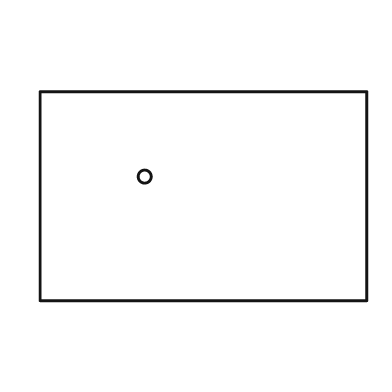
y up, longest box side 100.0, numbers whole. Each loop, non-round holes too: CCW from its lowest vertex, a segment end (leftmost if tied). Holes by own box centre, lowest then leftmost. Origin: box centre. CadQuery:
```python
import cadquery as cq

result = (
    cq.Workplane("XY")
    .moveTo(-50.0, -32.0)
    .lineTo(50.0, -32.0)
    .lineTo(50.0, 32.0)
    .lineTo(-50.0, 32.0)
    .close()
    .moveTo(-18.0, 6.0)
    .circle(2.0)
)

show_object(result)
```